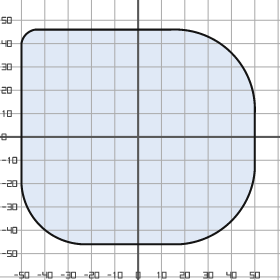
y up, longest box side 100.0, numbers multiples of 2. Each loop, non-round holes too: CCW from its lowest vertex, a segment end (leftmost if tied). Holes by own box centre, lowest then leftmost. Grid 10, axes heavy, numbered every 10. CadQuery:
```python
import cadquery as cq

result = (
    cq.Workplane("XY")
    .moveTo(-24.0, -46.0)
    .lineTo(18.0, -46.0)
    .threePointArc((40.0, -36.0), (50.0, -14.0))
    .lineTo(50.0, 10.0)
    .threePointArc((40.0, 36.0), (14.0, 46.0))
    .lineTo(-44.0, 46.0)
    .threePointArc((-48.0, 44.0), (-50.0, 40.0))
    .lineTo(-50.0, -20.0)
    .threePointArc((-42.0, -38.0), (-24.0, -46.0))
    .close()
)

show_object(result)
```